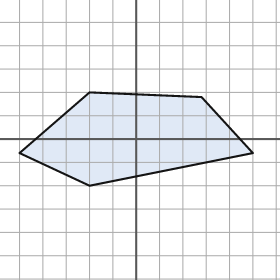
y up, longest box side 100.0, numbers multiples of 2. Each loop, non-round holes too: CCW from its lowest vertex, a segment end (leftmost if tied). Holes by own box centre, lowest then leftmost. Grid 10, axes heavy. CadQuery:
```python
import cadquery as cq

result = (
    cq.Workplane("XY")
    .moveTo(-20.0, -20.0)
    .lineTo(50.0, -6.0)
    .lineTo(28.0, 18.0)
    .lineTo(-20.0, 20.0)
    .lineTo(-50.0, -6.0)
    .close()
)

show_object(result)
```